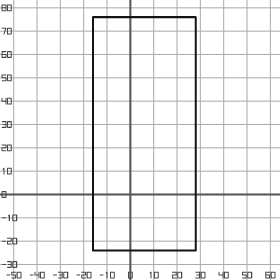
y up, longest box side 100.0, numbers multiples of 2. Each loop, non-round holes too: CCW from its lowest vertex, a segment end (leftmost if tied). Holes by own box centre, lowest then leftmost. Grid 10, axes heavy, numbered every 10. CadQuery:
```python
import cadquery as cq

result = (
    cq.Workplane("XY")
    .moveTo(-16.0, -24.0)
    .lineTo(28.0, -24.0)
    .lineTo(28.0, 76.0)
    .lineTo(-16.0, 76.0)
    .close()
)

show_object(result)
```